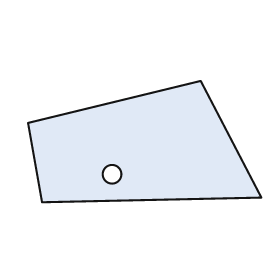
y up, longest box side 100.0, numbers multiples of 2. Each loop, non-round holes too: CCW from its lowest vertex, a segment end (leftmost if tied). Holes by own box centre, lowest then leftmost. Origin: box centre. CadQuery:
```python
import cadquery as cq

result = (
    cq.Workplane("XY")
    .moveTo(-44.0, -26.0)
    .lineTo(50.0, -24.0)
    .lineTo(24.0, 26.0)
    .lineTo(-50.0, 8.0)
    .close()
    .moveTo(-14.0, -14.0)
    .circle(4.0)
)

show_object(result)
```